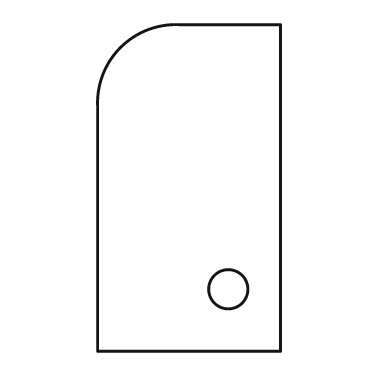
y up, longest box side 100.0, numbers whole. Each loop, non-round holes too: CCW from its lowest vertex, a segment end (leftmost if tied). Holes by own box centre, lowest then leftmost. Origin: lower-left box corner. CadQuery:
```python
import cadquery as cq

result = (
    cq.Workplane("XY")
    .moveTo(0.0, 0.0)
    .lineTo(56.0, 0.0)
    .lineTo(56.0, 100.0)
    .lineTo(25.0, 100.0)
    .threePointArc((7.0, 93.0), (0.0, 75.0))
    .close()
    .moveTo(40.0, 19.0)
    .circle(6.0)
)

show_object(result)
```